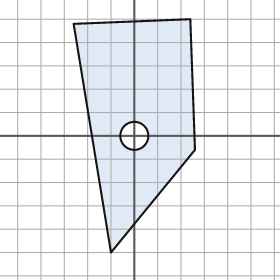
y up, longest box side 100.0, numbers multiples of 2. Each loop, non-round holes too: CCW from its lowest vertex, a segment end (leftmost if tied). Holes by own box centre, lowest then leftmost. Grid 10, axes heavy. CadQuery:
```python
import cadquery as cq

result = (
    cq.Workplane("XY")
    .moveTo(-10.0, -50.0)
    .lineTo(26.0, -6.0)
    .lineTo(24.0, 50.0)
    .lineTo(-26.0, 48.0)
    .close()
    .moveTo(0.0, 0.0)
    .circle(6.0)
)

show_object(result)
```